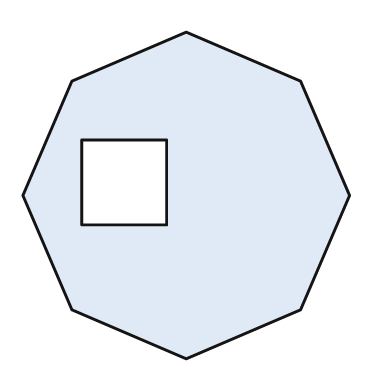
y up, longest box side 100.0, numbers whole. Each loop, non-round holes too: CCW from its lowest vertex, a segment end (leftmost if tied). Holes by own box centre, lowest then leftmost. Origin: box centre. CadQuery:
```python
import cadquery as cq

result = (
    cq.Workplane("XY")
    .moveTo(0.0, -50.0)
    .lineTo(35.0, -35.0)
    .lineTo(50.0, 0.0)
    .lineTo(35.0, 35.0)
    .lineTo(0.0, 50.0)
    .lineTo(-35.0, 35.0)
    .lineTo(-50.0, 0.0)
    .lineTo(-35.0, -35.0)
    .close()
    .moveTo(-32.0, -9.0)
    .lineTo(-6.0, -9.0)
    .lineTo(-6.0, 17.0)
    .lineTo(-32.0, 17.0)
    .close()
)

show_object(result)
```